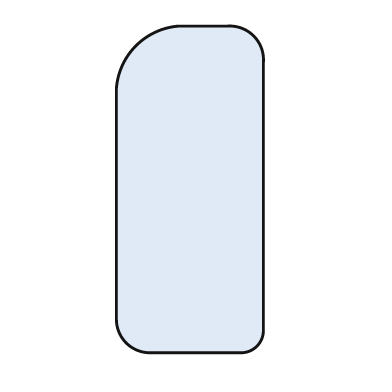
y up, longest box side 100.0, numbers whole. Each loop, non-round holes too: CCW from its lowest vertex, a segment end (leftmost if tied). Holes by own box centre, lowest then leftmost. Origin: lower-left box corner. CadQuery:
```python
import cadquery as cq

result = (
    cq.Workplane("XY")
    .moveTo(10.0, 0.0)
    .lineTo(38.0, 0.0)
    .threePointArc((43.0, 2.0), (45.0, 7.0))
    .lineTo(45.0, 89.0)
    .threePointArc((42.0, 97.0), (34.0, 100.0))
    .lineTo(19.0, 100.0)
    .threePointArc((6.0, 94.0), (0.0, 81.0))
    .lineTo(0.0, 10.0)
    .threePointArc((3.0, 3.0), (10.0, 0.0))
    .close()
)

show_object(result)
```